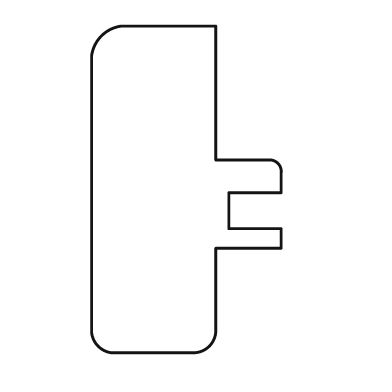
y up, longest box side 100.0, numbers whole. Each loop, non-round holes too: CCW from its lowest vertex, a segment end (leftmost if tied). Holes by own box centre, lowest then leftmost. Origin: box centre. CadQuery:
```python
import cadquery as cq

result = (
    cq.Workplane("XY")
    .moveTo(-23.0, -50.0)
    .lineTo(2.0, -50.0)
    .threePointArc((7.0, -48.0), (9.0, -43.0))
    .lineTo(9.0, -18.0)
    .lineTo(29.0, -18.0)
    .lineTo(29.0, -12.0)
    .lineTo(13.0, -12.0)
    .lineTo(13.0, -1.0)
    .lineTo(29.0, -1.0)
    .lineTo(29.0, 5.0)
    .threePointArc((28.0, 8.0), (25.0, 9.0))
    .lineTo(9.0, 9.0)
    .lineTo(9.0, 50.0)
    .lineTo(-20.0, 50.0)
    .threePointArc((-26.0, 47.0), (-29.0, 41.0))
    .lineTo(-29.0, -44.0)
    .threePointArc((-27.0, -48.0), (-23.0, -50.0))
    .close()
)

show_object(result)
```